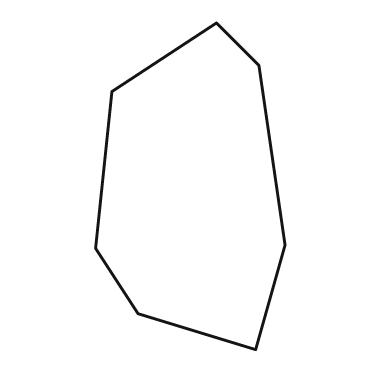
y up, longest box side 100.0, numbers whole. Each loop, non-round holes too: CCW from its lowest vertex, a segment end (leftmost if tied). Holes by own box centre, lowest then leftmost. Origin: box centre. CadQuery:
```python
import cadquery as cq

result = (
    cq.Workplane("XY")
    .moveTo(20.0, -50.0)
    .lineTo(29.0, -18.0)
    .lineTo(21.0, 37.0)
    .lineTo(8.0, 50.0)
    .lineTo(-24.0, 29.0)
    .lineTo(-29.0, -19.0)
    .lineTo(-16.0, -39.0)
    .close()
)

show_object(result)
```